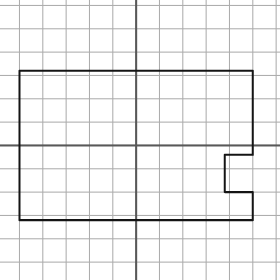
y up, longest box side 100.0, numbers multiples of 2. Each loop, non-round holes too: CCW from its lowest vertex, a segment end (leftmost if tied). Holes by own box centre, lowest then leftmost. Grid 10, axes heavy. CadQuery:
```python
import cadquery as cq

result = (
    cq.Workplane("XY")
    .moveTo(-50.0, -32.0)
    .lineTo(50.0, -32.0)
    .lineTo(50.0, -20.0)
    .lineTo(38.0, -20.0)
    .lineTo(38.0, -4.0)
    .lineTo(50.0, -4.0)
    .lineTo(50.0, 32.0)
    .lineTo(-50.0, 32.0)
    .close()
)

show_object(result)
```